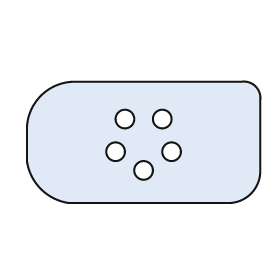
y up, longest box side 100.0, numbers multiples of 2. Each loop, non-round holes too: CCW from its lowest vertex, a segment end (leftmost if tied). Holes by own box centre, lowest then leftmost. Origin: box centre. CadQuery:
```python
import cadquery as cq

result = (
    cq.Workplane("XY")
    .moveTo(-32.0, -26.0)
    .lineTo(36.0, -26.0)
    .threePointArc((46.0, -22.0), (50.0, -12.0))
    .lineTo(50.0, 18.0)
    .threePointArc((48.0, 24.0), (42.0, 26.0))
    .lineTo(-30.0, 26.0)
    .threePointArc((-44.0, 20.0), (-50.0, 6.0))
    .lineTo(-50.0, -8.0)
    .threePointArc((-44.0, -20.0), (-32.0, -26.0))
    .close()
    .moveTo(0.0, -12.0)
    .circle(4.0)
    .moveTo(-12.0, -4.0)
    .circle(4.0)
    .moveTo(12.0, -4.0)
    .circle(4.0)
    .moveTo(-8.0, 10.0)
    .circle(4.0)
    .moveTo(8.0, 10.0)
    .circle(4.0)
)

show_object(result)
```